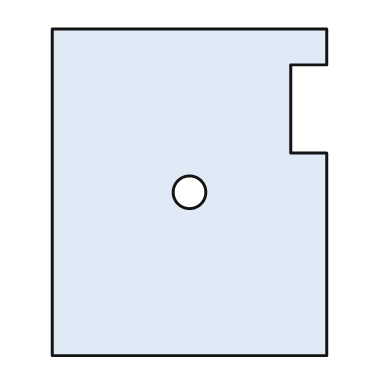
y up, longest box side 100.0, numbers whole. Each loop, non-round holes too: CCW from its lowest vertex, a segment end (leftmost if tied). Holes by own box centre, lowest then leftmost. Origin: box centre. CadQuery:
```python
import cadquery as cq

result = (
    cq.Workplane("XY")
    .moveTo(-42.0, -50.0)
    .lineTo(42.0, -50.0)
    .lineTo(42.0, 12.0)
    .lineTo(31.0, 12.0)
    .lineTo(31.0, 39.0)
    .lineTo(42.0, 39.0)
    .lineTo(42.0, 50.0)
    .lineTo(-42.0, 50.0)
    .close()
    .moveTo(0.0, 0.0)
    .circle(5.0)
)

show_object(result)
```